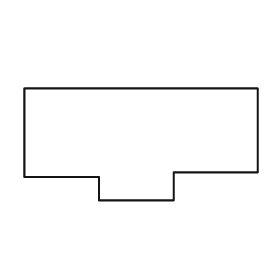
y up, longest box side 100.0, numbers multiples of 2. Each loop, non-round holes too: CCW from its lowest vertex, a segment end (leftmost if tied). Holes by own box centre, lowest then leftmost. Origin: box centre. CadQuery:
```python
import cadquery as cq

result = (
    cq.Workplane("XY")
    .moveTo(-18.0, -24.0)
    .lineTo(14.0, -24.0)
    .lineTo(14.0, -12.0)
    .lineTo(50.0, -12.0)
    .lineTo(50.0, 24.0)
    .lineTo(-50.0, 24.0)
    .lineTo(-50.0, -14.0)
    .lineTo(-18.0, -14.0)
    .close()
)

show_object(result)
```